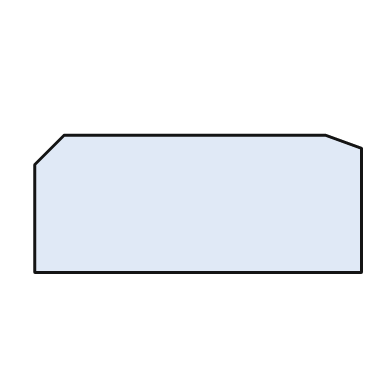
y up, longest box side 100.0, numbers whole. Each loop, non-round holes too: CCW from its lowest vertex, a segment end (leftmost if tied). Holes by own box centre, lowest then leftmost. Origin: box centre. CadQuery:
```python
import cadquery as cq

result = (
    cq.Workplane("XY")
    .moveTo(-50.0, -21.0)
    .lineTo(50.0, -21.0)
    .lineTo(50.0, 17.0)
    .lineTo(39.0, 21.0)
    .lineTo(-41.0, 21.0)
    .lineTo(-50.0, 12.0)
    .close()
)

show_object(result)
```